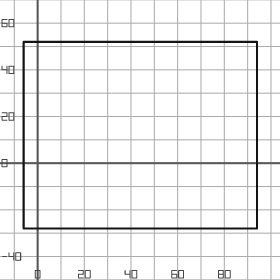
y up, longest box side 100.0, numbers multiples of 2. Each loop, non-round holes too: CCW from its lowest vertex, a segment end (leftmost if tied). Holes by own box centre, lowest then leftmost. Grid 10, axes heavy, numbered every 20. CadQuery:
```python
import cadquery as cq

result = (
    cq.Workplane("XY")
    .moveTo(-6.0, -28.0)
    .lineTo(94.0, -28.0)
    .lineTo(94.0, 52.0)
    .lineTo(-6.0, 52.0)
    .close()
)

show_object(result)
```